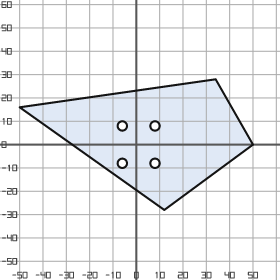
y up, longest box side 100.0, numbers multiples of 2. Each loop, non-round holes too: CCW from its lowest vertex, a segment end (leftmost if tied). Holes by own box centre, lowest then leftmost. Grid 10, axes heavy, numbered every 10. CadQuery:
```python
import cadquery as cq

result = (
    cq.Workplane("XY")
    .moveTo(12.0, -28.0)
    .lineTo(50.0, 0.0)
    .lineTo(34.0, 28.0)
    .lineTo(-50.0, 16.0)
    .close()
    .moveTo(-6.0, -8.0)
    .circle(2.0)
    .moveTo(8.0, -8.0)
    .circle(2.0)
    .moveTo(-6.0, 8.0)
    .circle(2.0)
    .moveTo(8.0, 8.0)
    .circle(2.0)
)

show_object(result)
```